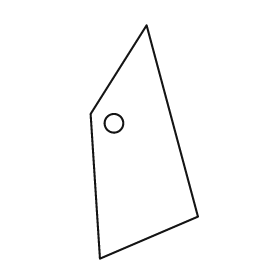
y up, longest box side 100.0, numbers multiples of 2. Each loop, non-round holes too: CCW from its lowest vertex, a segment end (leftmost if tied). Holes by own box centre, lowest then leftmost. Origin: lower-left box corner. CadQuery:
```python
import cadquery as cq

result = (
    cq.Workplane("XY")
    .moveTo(4.0, 0.0)
    .lineTo(46.0, 18.0)
    .lineTo(24.0, 100.0)
    .lineTo(0.0, 62.0)
    .close()
    .moveTo(10.0, 58.0)
    .circle(4.0)
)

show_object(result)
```